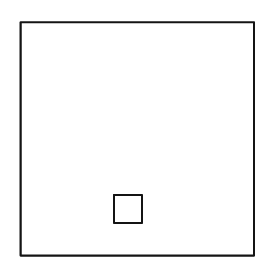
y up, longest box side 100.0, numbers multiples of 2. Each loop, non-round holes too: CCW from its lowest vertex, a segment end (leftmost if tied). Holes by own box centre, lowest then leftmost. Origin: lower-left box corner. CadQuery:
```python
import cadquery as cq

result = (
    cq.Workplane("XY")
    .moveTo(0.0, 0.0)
    .lineTo(100.0, 0.0)
    .lineTo(100.0, 100.0)
    .lineTo(0.0, 100.0)
    .close()
    .moveTo(40.0, 14.0)
    .lineTo(52.0, 14.0)
    .lineTo(52.0, 26.0)
    .lineTo(40.0, 26.0)
    .close()
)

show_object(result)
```